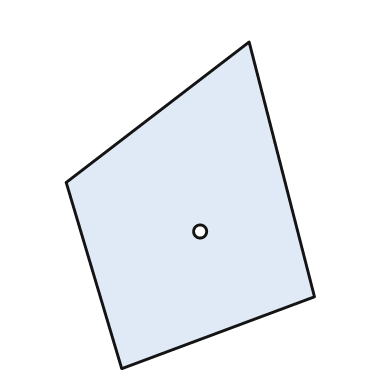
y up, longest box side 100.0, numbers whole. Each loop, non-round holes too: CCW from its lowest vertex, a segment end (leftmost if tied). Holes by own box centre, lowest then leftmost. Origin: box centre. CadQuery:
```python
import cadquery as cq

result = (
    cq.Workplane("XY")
    .moveTo(-21.0, -50.0)
    .lineTo(38.0, -28.0)
    .lineTo(18.0, 50.0)
    .lineTo(-38.0, 7.0)
    .close()
    .moveTo(3.0, -8.0)
    .circle(2.0)
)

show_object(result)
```